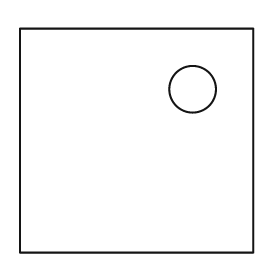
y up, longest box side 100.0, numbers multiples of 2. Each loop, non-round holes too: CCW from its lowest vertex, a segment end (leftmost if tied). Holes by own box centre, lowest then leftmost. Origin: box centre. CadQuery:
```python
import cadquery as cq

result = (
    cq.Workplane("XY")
    .moveTo(-50.0, -48.0)
    .lineTo(50.0, -48.0)
    .lineTo(50.0, 48.0)
    .lineTo(-50.0, 48.0)
    .close()
    .moveTo(24.0, 22.0)
    .circle(10.0)
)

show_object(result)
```